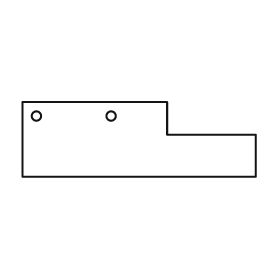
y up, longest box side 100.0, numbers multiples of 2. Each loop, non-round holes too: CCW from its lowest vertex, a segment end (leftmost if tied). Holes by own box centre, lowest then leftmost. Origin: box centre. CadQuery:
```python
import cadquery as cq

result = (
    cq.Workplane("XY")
    .moveTo(-50.0, -16.0)
    .lineTo(50.0, -16.0)
    .lineTo(50.0, 2.0)
    .lineTo(12.0, 2.0)
    .lineTo(12.0, 16.0)
    .lineTo(-50.0, 16.0)
    .close()
    .moveTo(-44.0, 10.0)
    .circle(2.0)
    .moveTo(-12.0, 10.0)
    .circle(2.0)
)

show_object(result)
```